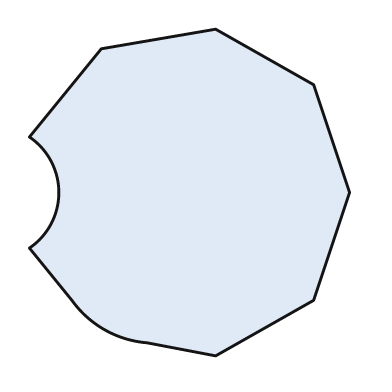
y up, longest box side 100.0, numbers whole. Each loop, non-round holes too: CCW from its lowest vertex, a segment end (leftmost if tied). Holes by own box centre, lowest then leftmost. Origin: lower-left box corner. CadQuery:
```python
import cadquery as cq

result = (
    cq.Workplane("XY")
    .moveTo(57.0, 0.0)
    .lineTo(87.0, 17.0)
    .lineTo(98.0, 50.0)
    .lineTo(87.0, 83.0)
    .lineTo(57.0, 100.0)
    .lineTo(22.0, 94.0)
    .lineTo(0.0, 67.0)
    .threePointArc((9.0, 50.0), (0.0, 33.0))
    .lineTo(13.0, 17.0)
    .threePointArc((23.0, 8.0), (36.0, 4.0))
    .close()
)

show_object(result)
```